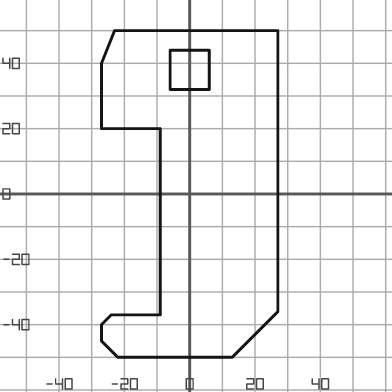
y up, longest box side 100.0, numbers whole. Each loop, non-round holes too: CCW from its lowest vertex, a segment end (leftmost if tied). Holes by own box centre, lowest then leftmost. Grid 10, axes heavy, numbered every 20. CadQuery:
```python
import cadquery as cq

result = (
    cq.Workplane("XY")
    .moveTo(-22.0, -50.0)
    .lineTo(13.0, -50.0)
    .lineTo(27.0, -36.0)
    .lineTo(27.0, 50.0)
    .lineTo(-23.0, 50.0)
    .lineTo(-27.0, 40.0)
    .lineTo(-27.0, 20.0)
    .lineTo(-9.0, 20.0)
    .lineTo(-9.0, -37.0)
    .lineTo(-24.0, -37.0)
    .lineTo(-27.0, -40.0)
    .lineTo(-27.0, -45.0)
    .close()
    .moveTo(-6.0, 32.0)
    .lineTo(6.0, 32.0)
    .lineTo(6.0, 44.0)
    .lineTo(-6.0, 44.0)
    .close()
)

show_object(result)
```